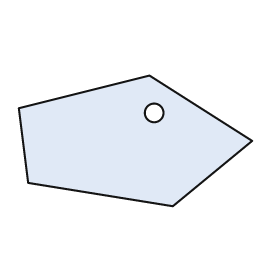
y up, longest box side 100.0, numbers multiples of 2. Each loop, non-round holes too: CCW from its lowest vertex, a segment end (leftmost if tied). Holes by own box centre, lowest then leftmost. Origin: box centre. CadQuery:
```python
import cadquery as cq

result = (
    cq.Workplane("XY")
    .moveTo(16.0, -28.0)
    .lineTo(50.0, 0.0)
    .lineTo(6.0, 28.0)
    .lineTo(-50.0, 14.0)
    .lineTo(-46.0, -18.0)
    .close()
    .moveTo(8.0, 12.0)
    .circle(4.0)
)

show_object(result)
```